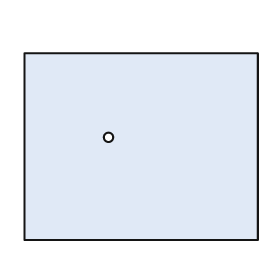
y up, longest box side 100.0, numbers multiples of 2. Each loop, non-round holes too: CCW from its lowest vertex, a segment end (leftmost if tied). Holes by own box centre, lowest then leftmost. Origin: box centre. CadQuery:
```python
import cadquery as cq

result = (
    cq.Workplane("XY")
    .moveTo(-50.0, -40.0)
    .lineTo(50.0, -40.0)
    .lineTo(50.0, 40.0)
    .lineTo(-50.0, 40.0)
    .close()
    .moveTo(-14.0, 4.0)
    .circle(2.0)
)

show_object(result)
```